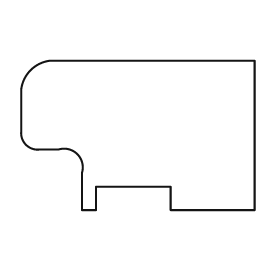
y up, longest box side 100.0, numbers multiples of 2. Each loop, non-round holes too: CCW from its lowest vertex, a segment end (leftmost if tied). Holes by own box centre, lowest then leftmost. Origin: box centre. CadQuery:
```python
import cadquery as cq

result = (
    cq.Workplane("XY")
    .moveTo(-24.0, -32.0)
    .lineTo(-18.0, -32.0)
    .lineTo(-18.0, -22.0)
    .lineTo(14.0, -22.0)
    .lineTo(14.0, -32.0)
    .lineTo(50.0, -32.0)
    .lineTo(50.0, 32.0)
    .lineTo(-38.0, 32.0)
    .threePointArc((-46.0, 28.0), (-50.0, 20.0))
    .lineTo(-50.0, 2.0)
    .threePointArc((-48.0, -4.0), (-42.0, -6.0))
    .lineTo(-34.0, -6.0)
    .threePointArc((-26.0, -8.0), (-24.0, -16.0))
    .close()
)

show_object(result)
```